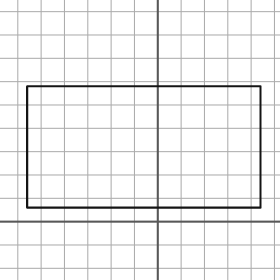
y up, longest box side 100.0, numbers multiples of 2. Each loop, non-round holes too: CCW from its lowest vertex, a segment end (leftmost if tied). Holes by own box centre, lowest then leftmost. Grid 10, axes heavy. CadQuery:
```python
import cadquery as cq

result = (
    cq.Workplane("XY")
    .moveTo(-56.0, 6.0)
    .lineTo(44.0, 6.0)
    .lineTo(44.0, 58.0)
    .lineTo(-56.0, 58.0)
    .close()
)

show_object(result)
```